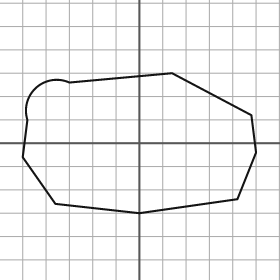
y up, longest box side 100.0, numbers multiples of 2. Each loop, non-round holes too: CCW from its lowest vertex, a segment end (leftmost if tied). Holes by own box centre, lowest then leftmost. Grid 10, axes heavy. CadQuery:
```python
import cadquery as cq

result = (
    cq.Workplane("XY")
    .moveTo(0.0, -30.0)
    .lineTo(42.0, -24.0)
    .lineTo(50.0, -4.0)
    .lineTo(48.0, 12.0)
    .lineTo(14.0, 30.0)
    .lineTo(-30.0, 26.0)
    .threePointArc((-44.0, 24.0), (-48.0, 10.0))
    .lineTo(-50.0, -6.0)
    .lineTo(-36.0, -26.0)
    .close()
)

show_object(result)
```